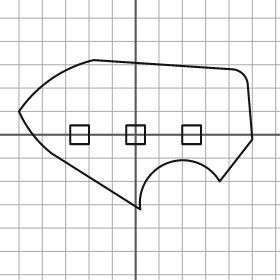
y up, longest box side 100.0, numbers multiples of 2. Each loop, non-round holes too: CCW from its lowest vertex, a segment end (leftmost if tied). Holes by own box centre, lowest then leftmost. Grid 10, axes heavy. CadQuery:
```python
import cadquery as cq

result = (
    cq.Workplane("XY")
    .moveTo(2.0, -32.0)
    .threePointArc((14.0, -12.0), (36.0, -20.0))
    .lineTo(50.0, -2.0)
    .lineTo(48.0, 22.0)
    .threePointArc((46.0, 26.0), (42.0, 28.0))
    .lineTo(-18.0, 32.0)
    .threePointArc((-36.0, 24.0), (-50.0, 10.0))
    .threePointArc((-44.0, 0.0), (-36.0, -8.0))
    .close()
    .moveTo(-28.0, -4.0)
    .lineTo(-20.0, -4.0)
    .lineTo(-20.0, 4.0)
    .lineTo(-28.0, 4.0)
    .close()
    .moveTo(-4.0, -4.0)
    .lineTo(4.0, -4.0)
    .lineTo(4.0, 4.0)
    .lineTo(-4.0, 4.0)
    .close()
    .moveTo(20.0, -4.0)
    .lineTo(28.0, -4.0)
    .lineTo(28.0, 4.0)
    .lineTo(20.0, 4.0)
    .close()
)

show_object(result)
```